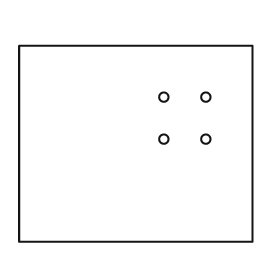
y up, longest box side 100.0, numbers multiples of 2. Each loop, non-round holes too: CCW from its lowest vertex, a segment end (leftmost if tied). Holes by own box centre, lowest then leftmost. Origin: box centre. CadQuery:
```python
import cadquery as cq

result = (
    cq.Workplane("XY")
    .moveTo(-50.0, -42.0)
    .lineTo(50.0, -42.0)
    .lineTo(50.0, 42.0)
    .lineTo(-50.0, 42.0)
    .close()
    .moveTo(12.0, 2.0)
    .circle(2.0)
    .moveTo(30.0, 2.0)
    .circle(2.0)
    .moveTo(12.0, 20.0)
    .circle(2.0)
    .moveTo(30.0, 20.0)
    .circle(2.0)
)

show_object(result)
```